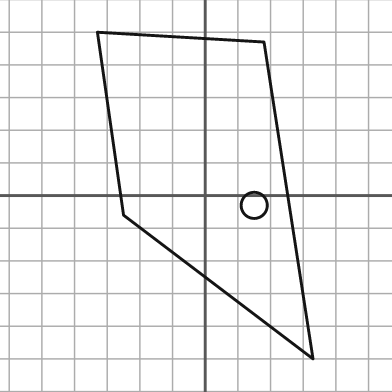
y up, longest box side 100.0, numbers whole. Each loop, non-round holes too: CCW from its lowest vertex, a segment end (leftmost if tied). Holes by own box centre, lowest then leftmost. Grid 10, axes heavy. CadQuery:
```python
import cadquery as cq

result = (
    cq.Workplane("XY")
    .moveTo(33.0, -50.0)
    .lineTo(18.0, 47.0)
    .lineTo(-33.0, 50.0)
    .lineTo(-25.0, -6.0)
    .close()
    .moveTo(15.0, -3.0)
    .circle(4.0)
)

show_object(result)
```